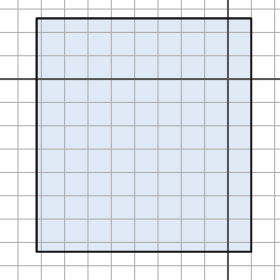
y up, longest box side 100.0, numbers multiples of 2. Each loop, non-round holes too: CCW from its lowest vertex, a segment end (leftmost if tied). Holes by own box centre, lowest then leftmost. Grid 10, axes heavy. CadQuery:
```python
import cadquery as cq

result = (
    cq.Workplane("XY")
    .moveTo(-82.0, -74.0)
    .lineTo(10.0, -74.0)
    .lineTo(10.0, 26.0)
    .lineTo(-82.0, 26.0)
    .close()
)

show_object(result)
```